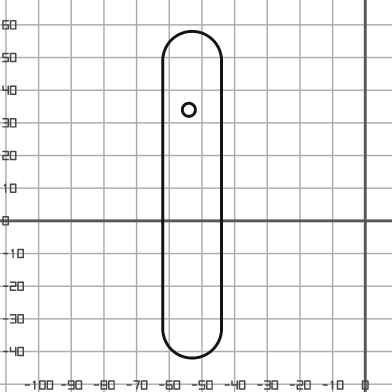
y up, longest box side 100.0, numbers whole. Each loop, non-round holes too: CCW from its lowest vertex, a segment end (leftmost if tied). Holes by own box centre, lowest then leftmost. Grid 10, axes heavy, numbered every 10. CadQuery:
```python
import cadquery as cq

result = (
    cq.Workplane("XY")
    .moveTo(-62.0, -33.0)
    .threePointArc((-53.0, -42.0), (-44.0, -33.0))
    .lineTo(-44.0, 49.0)
    .threePointArc((-53.0, 58.0), (-62.0, 49.0))
    .close()
    .moveTo(-54.0, 34.0)
    .circle(2.0)
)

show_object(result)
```